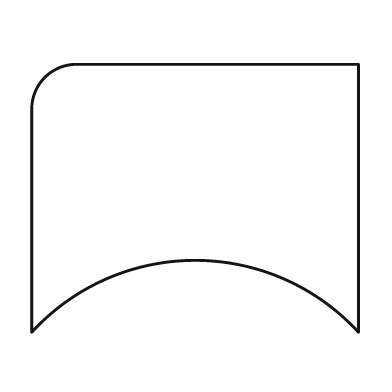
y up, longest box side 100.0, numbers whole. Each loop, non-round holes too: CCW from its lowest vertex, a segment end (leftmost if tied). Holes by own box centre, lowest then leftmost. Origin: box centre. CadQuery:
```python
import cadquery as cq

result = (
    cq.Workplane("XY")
    .moveTo(-50.0, -41.0)
    .threePointArc((0.0, -19.0), (50.0, -41.0))
    .lineTo(50.0, 41.0)
    .lineTo(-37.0, 41.0)
    .threePointArc((-46.0, 37.0), (-50.0, 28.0))
    .close()
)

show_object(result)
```